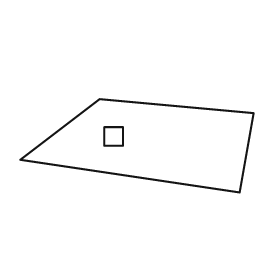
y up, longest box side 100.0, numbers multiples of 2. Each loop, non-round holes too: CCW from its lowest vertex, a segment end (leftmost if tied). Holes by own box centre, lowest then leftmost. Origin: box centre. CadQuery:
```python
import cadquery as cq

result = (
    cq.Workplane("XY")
    .moveTo(44.0, -20.0)
    .lineTo(50.0, 14.0)
    .lineTo(-16.0, 20.0)
    .lineTo(-50.0, -6.0)
    .close()
    .moveTo(-14.0, 0.0)
    .lineTo(-6.0, 0.0)
    .lineTo(-6.0, 8.0)
    .lineTo(-14.0, 8.0)
    .close()
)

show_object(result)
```